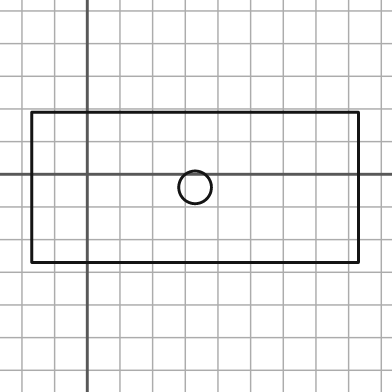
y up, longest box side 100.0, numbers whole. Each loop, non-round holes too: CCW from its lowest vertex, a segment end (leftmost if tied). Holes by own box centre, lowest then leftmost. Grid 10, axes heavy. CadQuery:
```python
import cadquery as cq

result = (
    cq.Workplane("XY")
    .moveTo(-17.0, -27.0)
    .lineTo(83.0, -27.0)
    .lineTo(83.0, 19.0)
    .lineTo(-17.0, 19.0)
    .close()
    .moveTo(33.0, -4.0)
    .circle(5.0)
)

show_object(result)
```